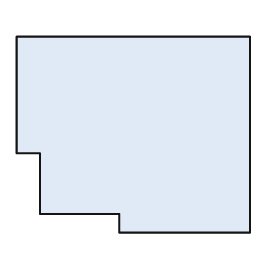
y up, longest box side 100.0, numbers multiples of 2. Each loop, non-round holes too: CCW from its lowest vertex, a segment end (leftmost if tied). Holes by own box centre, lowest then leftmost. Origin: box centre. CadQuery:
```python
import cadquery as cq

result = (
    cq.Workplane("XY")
    .moveTo(-6.0, -42.0)
    .lineTo(50.0, -42.0)
    .lineTo(50.0, 42.0)
    .lineTo(-50.0, 42.0)
    .lineTo(-50.0, -8.0)
    .lineTo(-40.0, -8.0)
    .lineTo(-40.0, -34.0)
    .lineTo(-6.0, -34.0)
    .close()
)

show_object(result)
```